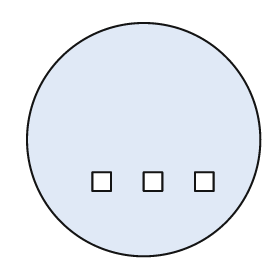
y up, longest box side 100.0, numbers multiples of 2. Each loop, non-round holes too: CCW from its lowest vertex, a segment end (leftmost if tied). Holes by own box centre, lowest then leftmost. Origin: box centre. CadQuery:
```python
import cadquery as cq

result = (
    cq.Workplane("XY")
    .moveTo(0.0, 0.0)
    .circle(50.0)
    .moveTo(-22.0, -22.0)
    .lineTo(-14.0, -22.0)
    .lineTo(-14.0, -14.0)
    .lineTo(-22.0, -14.0)
    .close()
    .moveTo(0.0, -22.0)
    .lineTo(8.0, -22.0)
    .lineTo(8.0, -14.0)
    .lineTo(0.0, -14.0)
    .close()
    .moveTo(22.0, -22.0)
    .lineTo(30.0, -22.0)
    .lineTo(30.0, -14.0)
    .lineTo(22.0, -14.0)
    .close()
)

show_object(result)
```